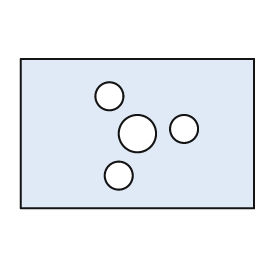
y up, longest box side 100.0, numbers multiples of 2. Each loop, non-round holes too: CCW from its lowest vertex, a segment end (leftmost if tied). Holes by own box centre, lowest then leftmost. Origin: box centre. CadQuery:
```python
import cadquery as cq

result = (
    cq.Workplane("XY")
    .moveTo(-50.0, -32.0)
    .lineTo(50.0, -32.0)
    .lineTo(50.0, 32.0)
    .lineTo(-50.0, 32.0)
    .close()
    .moveTo(-8.0, -18.0)
    .circle(6.0)
    .moveTo(0.0, 0.0)
    .circle(8.0)
    .moveTo(20.0, 2.0)
    .circle(6.0)
    .moveTo(-12.0, 16.0)
    .circle(6.0)
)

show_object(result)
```